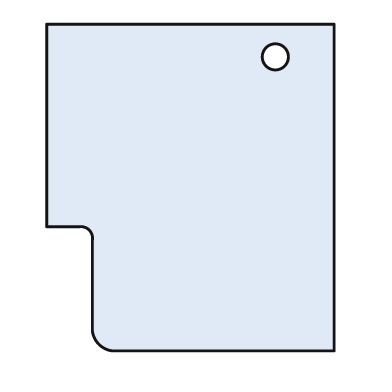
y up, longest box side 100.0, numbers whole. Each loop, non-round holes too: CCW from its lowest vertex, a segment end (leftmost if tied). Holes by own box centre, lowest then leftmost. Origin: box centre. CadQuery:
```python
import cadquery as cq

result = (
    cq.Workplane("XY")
    .moveTo(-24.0, -50.0)
    .lineTo(44.0, -50.0)
    .lineTo(44.0, 50.0)
    .lineTo(-44.0, 50.0)
    .lineTo(-44.0, -12.0)
    .lineTo(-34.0, -12.0)
    .threePointArc((-31.0, -13.0), (-30.0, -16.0))
    .lineTo(-30.0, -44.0)
    .threePointArc((-28.0, -48.0), (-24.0, -50.0))
    .close()
    .moveTo(26.0, 40.0)
    .circle(4.0)
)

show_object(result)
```